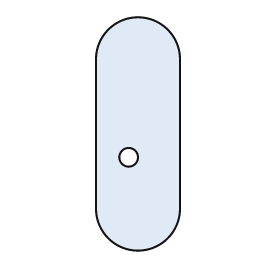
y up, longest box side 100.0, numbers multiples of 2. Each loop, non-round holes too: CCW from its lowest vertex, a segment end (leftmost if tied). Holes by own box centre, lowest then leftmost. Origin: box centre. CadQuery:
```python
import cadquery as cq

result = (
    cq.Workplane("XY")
    .moveTo(-18.0, -32.0)
    .threePointArc((0.0, -50.0), (18.0, -32.0))
    .lineTo(18.0, 32.0)
    .threePointArc((0.0, 50.0), (-18.0, 32.0))
    .close()
    .moveTo(-4.0, -10.0)
    .circle(4.0)
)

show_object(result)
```